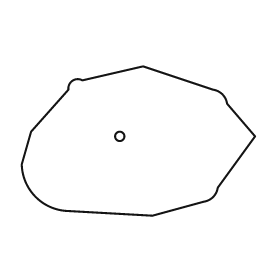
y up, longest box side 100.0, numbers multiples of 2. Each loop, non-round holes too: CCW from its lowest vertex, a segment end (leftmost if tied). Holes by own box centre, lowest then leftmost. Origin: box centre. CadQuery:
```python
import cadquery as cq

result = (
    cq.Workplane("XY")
    .moveTo(6.0, -32.0)
    .lineTo(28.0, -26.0)
    .threePointArc((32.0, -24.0), (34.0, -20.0))
    .lineTo(50.0, 2.0)
    .lineTo(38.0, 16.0)
    .threePointArc((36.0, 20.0), (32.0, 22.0))
    .lineTo(2.0, 32.0)
    .lineTo(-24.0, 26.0)
    .threePointArc((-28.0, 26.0), (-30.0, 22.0))
    .lineTo(-46.0, 4.0)
    .lineTo(-50.0, -10.0)
    .threePointArc((-44.0, -24.0), (-30.0, -30.0))
    .close()
    .moveTo(-8.0, 2.0)
    .circle(2.0)
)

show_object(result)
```